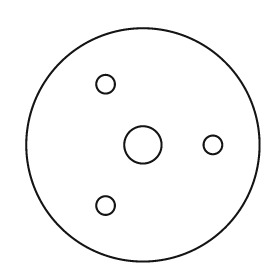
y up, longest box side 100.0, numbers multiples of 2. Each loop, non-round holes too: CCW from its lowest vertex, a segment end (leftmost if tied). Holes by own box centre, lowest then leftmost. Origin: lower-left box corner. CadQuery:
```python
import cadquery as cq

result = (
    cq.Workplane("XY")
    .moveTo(50.0, 50.0)
    .circle(50.0)
    .moveTo(34.0, 24.0)
    .circle(4.0)
    .moveTo(50.0, 50.0)
    .circle(8.0)
    .moveTo(80.0, 50.0)
    .circle(4.0)
    .moveTo(34.0, 76.0)
    .circle(4.0)
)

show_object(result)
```